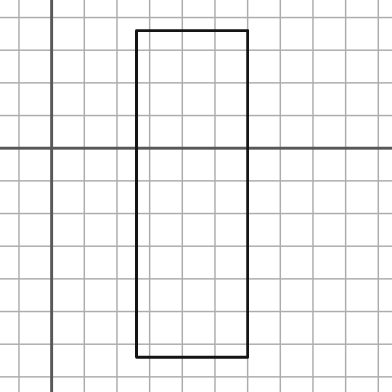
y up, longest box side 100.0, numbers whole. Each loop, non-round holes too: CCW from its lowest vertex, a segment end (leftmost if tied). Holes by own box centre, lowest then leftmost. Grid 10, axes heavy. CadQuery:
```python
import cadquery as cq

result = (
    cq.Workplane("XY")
    .moveTo(26.0, -64.0)
    .lineTo(60.0, -64.0)
    .lineTo(60.0, 36.0)
    .lineTo(26.0, 36.0)
    .close()
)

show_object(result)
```